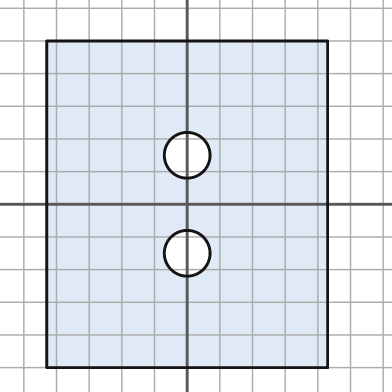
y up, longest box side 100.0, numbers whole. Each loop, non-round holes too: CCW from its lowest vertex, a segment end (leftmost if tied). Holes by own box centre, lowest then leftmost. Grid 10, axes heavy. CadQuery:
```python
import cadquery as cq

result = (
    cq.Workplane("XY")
    .moveTo(-43.0, -50.0)
    .lineTo(43.0, -50.0)
    .lineTo(43.0, 50.0)
    .lineTo(-43.0, 50.0)
    .close()
    .moveTo(0.0, -15.0)
    .circle(7.0)
    .moveTo(0.0, 15.0)
    .circle(7.0)
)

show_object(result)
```